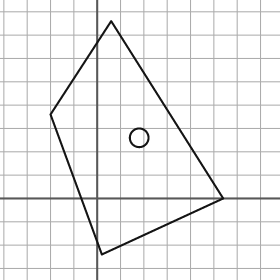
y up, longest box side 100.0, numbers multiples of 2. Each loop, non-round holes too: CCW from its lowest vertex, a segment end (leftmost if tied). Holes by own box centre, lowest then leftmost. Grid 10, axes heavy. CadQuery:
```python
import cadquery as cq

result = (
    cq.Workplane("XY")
    .moveTo(2.0, -24.0)
    .lineTo(54.0, 0.0)
    .lineTo(6.0, 76.0)
    .lineTo(-20.0, 36.0)
    .close()
    .moveTo(18.0, 26.0)
    .circle(4.0)
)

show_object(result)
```